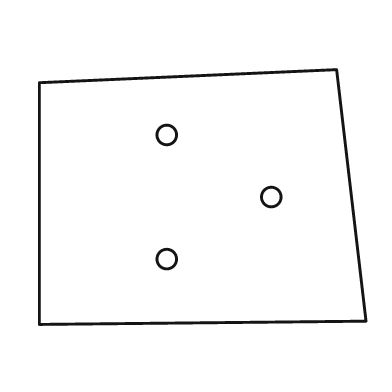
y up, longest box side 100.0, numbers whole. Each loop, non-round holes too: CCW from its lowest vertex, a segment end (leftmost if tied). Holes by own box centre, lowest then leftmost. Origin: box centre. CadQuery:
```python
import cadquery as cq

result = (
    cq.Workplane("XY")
    .moveTo(-50.0, -39.0)
    .lineTo(50.0, -38.0)
    .lineTo(41.0, 39.0)
    .lineTo(-50.0, 35.0)
    .close()
    .moveTo(-11.0, -19.0)
    .circle(3.0)
    .moveTo(21.0, 0.0)
    .circle(3.0)
    .moveTo(-11.0, 19.0)
    .circle(3.0)
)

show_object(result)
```